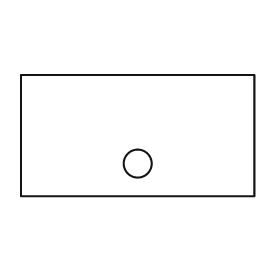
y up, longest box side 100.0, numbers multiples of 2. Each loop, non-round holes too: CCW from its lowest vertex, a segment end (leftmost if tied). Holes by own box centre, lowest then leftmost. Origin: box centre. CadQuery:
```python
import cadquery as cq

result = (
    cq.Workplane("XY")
    .moveTo(-50.0, -26.0)
    .lineTo(50.0, -26.0)
    .lineTo(50.0, 26.0)
    .lineTo(-50.0, 26.0)
    .close()
    .moveTo(0.0, -12.0)
    .circle(6.0)
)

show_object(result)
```